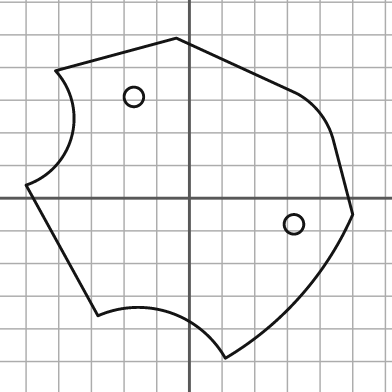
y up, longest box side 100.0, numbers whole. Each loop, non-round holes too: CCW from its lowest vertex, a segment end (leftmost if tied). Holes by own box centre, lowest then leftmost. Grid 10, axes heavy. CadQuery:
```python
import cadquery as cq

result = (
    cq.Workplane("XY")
    .moveTo(11.0, -49.0)
    .threePointArc((34.0, -30.0), (50.0, -5.0))
    .lineTo(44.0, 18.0)
    .threePointArc((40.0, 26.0), (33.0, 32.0))
    .lineTo(-4.0, 49.0)
    .lineTo(-41.0, 39.0)
    .threePointArc((-36.0, 19.0), (-50.0, 4.0))
    .lineTo(-28.0, -36.0)
    .threePointArc((-6.0, -35.0), (11.0, -49.0))
    .close()
    .moveTo(32.0, -8.0)
    .circle(3.0)
    .moveTo(-17.0, 31.0)
    .circle(3.0)
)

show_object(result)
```